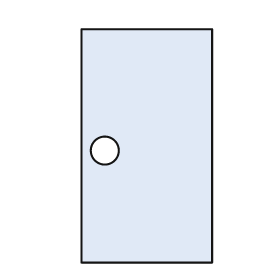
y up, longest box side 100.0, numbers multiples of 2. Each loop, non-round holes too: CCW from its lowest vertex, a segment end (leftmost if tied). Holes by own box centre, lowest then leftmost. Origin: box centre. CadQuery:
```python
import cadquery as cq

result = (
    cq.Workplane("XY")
    .moveTo(-28.0, -50.0)
    .lineTo(28.0, -50.0)
    .lineTo(28.0, 50.0)
    .lineTo(-28.0, 50.0)
    .close()
    .moveTo(-18.0, -2.0)
    .circle(6.0)
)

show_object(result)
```